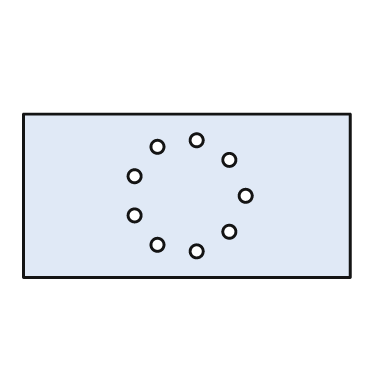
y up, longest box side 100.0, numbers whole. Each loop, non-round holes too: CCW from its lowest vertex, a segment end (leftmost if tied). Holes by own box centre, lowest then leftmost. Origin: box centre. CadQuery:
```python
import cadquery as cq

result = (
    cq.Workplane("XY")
    .moveTo(-50.0, -25.0)
    .lineTo(50.0, -25.0)
    .lineTo(50.0, 25.0)
    .lineTo(-50.0, 25.0)
    .close()
    .moveTo(3.0, -17.0)
    .circle(2.0)
    .moveTo(-9.0, -15.0)
    .circle(2.0)
    .moveTo(13.0, -11.0)
    .circle(2.0)
    .moveTo(-16.0, -6.0)
    .circle(2.0)
    .moveTo(18.0, 0.0)
    .circle(2.0)
    .moveTo(-16.0, 6.0)
    .circle(2.0)
    .moveTo(13.0, 11.0)
    .circle(2.0)
    .moveTo(-9.0, 15.0)
    .circle(2.0)
    .moveTo(3.0, 17.0)
    .circle(2.0)
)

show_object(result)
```